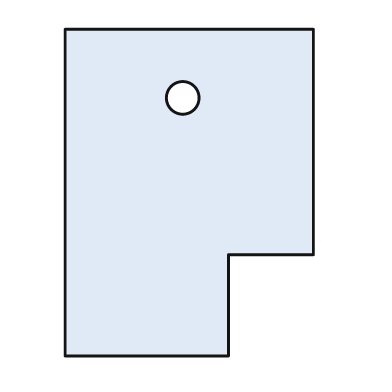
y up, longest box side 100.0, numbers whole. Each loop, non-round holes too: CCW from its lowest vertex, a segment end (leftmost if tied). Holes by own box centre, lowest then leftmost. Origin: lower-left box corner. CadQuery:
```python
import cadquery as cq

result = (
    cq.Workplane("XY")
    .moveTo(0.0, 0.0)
    .lineTo(50.0, 0.0)
    .lineTo(50.0, 31.0)
    .lineTo(76.0, 31.0)
    .lineTo(76.0, 100.0)
    .lineTo(0.0, 100.0)
    .close()
    .moveTo(36.0, 79.0)
    .circle(5.0)
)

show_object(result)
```